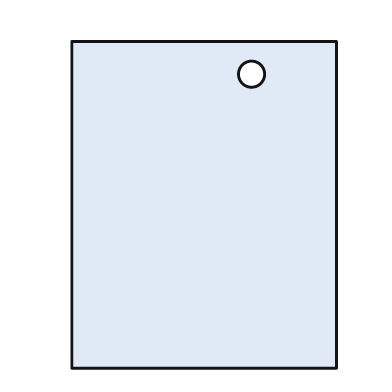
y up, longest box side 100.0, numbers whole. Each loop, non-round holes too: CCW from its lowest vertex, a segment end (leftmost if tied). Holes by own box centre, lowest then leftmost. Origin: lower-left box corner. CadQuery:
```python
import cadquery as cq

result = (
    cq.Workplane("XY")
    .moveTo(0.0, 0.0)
    .lineTo(81.0, 0.0)
    .lineTo(81.0, 100.0)
    .lineTo(0.0, 100.0)
    .close()
    .moveTo(55.0, 90.0)
    .circle(4.0)
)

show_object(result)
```